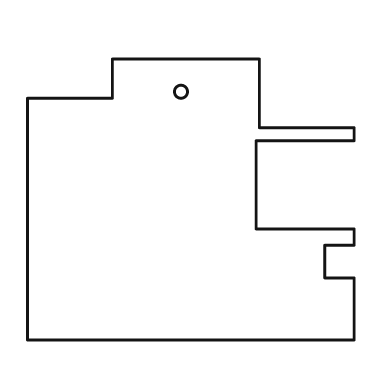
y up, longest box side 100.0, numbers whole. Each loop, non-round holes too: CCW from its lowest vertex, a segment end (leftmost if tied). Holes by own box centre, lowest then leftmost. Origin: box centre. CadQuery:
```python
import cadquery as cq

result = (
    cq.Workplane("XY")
    .moveTo(-50.0, -43.0)
    .lineTo(50.0, -43.0)
    .lineTo(50.0, -24.0)
    .lineTo(41.0, -24.0)
    .lineTo(41.0, -14.0)
    .lineTo(50.0, -14.0)
    .lineTo(50.0, -9.0)
    .lineTo(20.0, -9.0)
    .lineTo(20.0, 18.0)
    .lineTo(50.0, 18.0)
    .lineTo(50.0, 22.0)
    .lineTo(21.0, 22.0)
    .lineTo(21.0, 43.0)
    .lineTo(-24.0, 43.0)
    .lineTo(-24.0, 31.0)
    .lineTo(-50.0, 31.0)
    .close()
    .moveTo(-3.0, 33.0)
    .circle(2.0)
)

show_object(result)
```